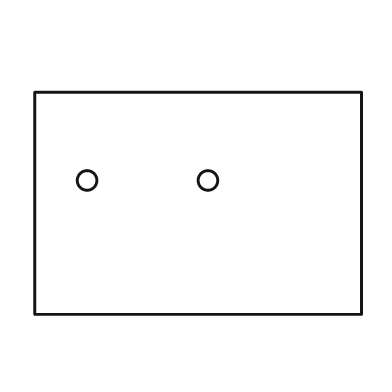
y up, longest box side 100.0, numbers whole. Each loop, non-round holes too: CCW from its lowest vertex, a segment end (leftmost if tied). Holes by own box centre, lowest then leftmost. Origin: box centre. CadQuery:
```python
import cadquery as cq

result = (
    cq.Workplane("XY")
    .moveTo(-50.0, -34.0)
    .lineTo(50.0, -34.0)
    .lineTo(50.0, 34.0)
    .lineTo(-50.0, 34.0)
    .close()
    .moveTo(-34.0, 7.0)
    .circle(3.0)
    .moveTo(3.0, 7.0)
    .circle(3.0)
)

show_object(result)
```